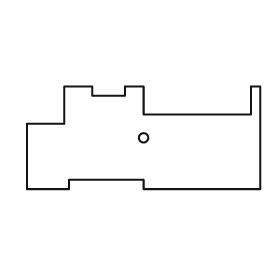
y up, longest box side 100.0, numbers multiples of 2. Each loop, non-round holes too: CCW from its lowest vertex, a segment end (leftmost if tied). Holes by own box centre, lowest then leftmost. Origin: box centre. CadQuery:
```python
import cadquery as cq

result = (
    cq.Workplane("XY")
    .moveTo(-50.0, -22.0)
    .lineTo(-32.0, -22.0)
    .lineTo(-32.0, -18.0)
    .lineTo(0.0, -18.0)
    .lineTo(0.0, -22.0)
    .lineTo(50.0, -22.0)
    .lineTo(50.0, 22.0)
    .lineTo(46.0, 22.0)
    .lineTo(46.0, 10.0)
    .lineTo(0.0, 10.0)
    .lineTo(0.0, 22.0)
    .lineTo(-8.0, 22.0)
    .lineTo(-8.0, 18.0)
    .lineTo(-22.0, 18.0)
    .lineTo(-22.0, 22.0)
    .lineTo(-34.0, 22.0)
    .lineTo(-34.0, 6.0)
    .lineTo(-50.0, 6.0)
    .close()
    .moveTo(0.0, 0.0)
    .circle(2.0)
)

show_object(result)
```